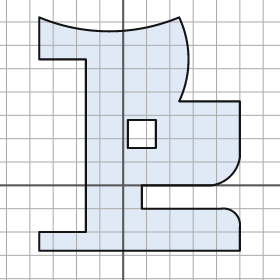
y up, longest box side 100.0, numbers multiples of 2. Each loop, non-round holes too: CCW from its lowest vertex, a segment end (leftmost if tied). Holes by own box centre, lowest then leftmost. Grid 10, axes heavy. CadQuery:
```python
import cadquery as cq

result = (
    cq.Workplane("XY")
    .moveTo(-36.0, -28.0)
    .lineTo(50.0, -28.0)
    .lineTo(50.0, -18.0)
    .threePointArc((48.0, -12.0), (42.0, -10.0))
    .lineTo(8.0, -10.0)
    .lineTo(8.0, 0.0)
    .lineTo(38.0, 0.0)
    .threePointArc((46.0, 4.0), (50.0, 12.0))
    .lineTo(50.0, 36.0)
    .lineTo(24.0, 36.0)
    .threePointArc((28.0, 54.0), (24.0, 72.0))
    .threePointArc((-6.0, 66.0), (-36.0, 72.0))
    .lineTo(-36.0, 54.0)
    .lineTo(-16.0, 54.0)
    .lineTo(-16.0, -20.0)
    .lineTo(-36.0, -20.0)
    .close()
    .moveTo(2.0, 16.0)
    .lineTo(14.0, 16.0)
    .lineTo(14.0, 28.0)
    .lineTo(2.0, 28.0)
    .close()
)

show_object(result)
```